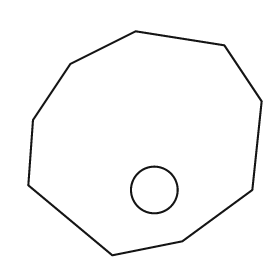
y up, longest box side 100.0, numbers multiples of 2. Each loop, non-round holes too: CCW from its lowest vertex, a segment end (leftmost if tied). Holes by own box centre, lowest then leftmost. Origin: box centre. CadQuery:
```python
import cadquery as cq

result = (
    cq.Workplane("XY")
    .moveTo(-14.0, -48.0)
    .lineTo(16.0, -42.0)
    .lineTo(46.0, -20.0)
    .lineTo(50.0, 18.0)
    .lineTo(34.0, 42.0)
    .lineTo(-4.0, 48.0)
    .lineTo(-32.0, 34.0)
    .lineTo(-48.0, 10.0)
    .lineTo(-50.0, -18.0)
    .close()
    .moveTo(4.0, -20.0)
    .circle(10.0)
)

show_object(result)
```